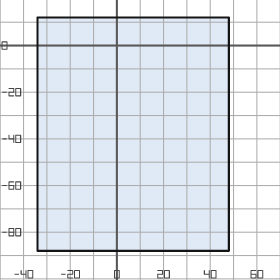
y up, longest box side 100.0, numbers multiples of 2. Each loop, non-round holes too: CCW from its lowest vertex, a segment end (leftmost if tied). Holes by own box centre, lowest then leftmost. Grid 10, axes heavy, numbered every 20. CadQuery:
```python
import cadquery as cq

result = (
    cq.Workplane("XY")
    .moveTo(-34.0, -88.0)
    .lineTo(48.0, -88.0)
    .lineTo(48.0, 12.0)
    .lineTo(-34.0, 12.0)
    .close()
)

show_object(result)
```